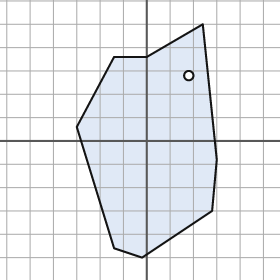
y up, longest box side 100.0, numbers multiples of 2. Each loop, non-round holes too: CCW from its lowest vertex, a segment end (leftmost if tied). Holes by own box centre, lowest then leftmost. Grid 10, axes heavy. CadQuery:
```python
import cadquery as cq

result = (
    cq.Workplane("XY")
    .moveTo(-2.0, -50.0)
    .lineTo(28.0, -30.0)
    .lineTo(30.0, -8.0)
    .lineTo(24.0, 50.0)
    .lineTo(0.0, 36.0)
    .lineTo(-14.0, 36.0)
    .lineTo(-30.0, 6.0)
    .lineTo(-14.0, -46.0)
    .close()
    .moveTo(18.0, 28.0)
    .circle(2.0)
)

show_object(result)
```